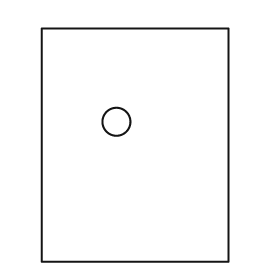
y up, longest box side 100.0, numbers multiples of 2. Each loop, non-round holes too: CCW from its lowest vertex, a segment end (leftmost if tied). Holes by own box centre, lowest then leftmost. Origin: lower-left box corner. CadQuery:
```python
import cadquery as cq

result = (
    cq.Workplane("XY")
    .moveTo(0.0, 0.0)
    .lineTo(80.0, 0.0)
    .lineTo(80.0, 100.0)
    .lineTo(0.0, 100.0)
    .close()
    .moveTo(32.0, 60.0)
    .circle(6.0)
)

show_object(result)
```